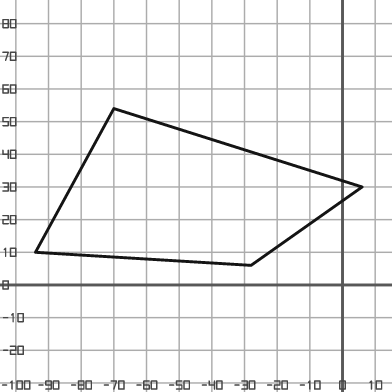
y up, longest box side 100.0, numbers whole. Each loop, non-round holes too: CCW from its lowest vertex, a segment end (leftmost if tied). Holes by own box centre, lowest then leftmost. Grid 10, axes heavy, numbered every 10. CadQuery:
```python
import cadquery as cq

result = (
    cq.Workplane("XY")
    .moveTo(-28.0, 6.0)
    .lineTo(6.0, 30.0)
    .lineTo(-70.0, 54.0)
    .lineTo(-94.0, 10.0)
    .close()
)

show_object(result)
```